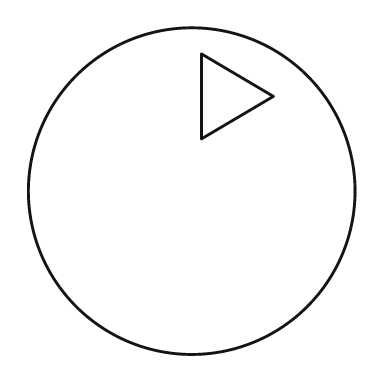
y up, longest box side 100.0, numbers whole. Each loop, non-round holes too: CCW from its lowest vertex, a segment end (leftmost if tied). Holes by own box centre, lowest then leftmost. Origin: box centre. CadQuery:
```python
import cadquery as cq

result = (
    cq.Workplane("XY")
    .moveTo(0.0, 0.0)
    .circle(50.0)
    .moveTo(3.0, 16.0)
    .lineTo(25.0, 29.0)
    .lineTo(3.0, 42.0)
    .close()
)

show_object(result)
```